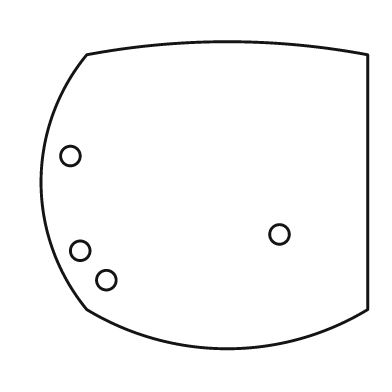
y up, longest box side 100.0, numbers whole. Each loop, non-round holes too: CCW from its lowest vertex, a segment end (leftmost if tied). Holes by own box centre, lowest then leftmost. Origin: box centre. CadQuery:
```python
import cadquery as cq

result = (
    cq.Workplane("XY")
    .moveTo(-36.0, -35.0)
    .threePointArc((7.0, -47.0), (50.0, -35.0))
    .lineTo(50.0, 43.0)
    .threePointArc((7.0, 47.0), (-36.0, 43.0))
    .threePointArc((-50.0, 4.0), (-36.0, -35.0))
    .close()
    .moveTo(-30.0, -26.0)
    .circle(3.0)
    .moveTo(-38.0, -17.0)
    .circle(3.0)
    .moveTo(23.0, -12.0)
    .circle(3.0)
    .moveTo(-41.0, 12.0)
    .circle(3.0)
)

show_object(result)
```